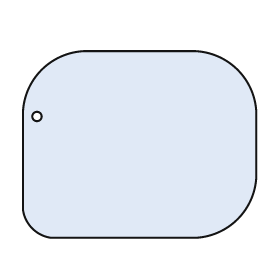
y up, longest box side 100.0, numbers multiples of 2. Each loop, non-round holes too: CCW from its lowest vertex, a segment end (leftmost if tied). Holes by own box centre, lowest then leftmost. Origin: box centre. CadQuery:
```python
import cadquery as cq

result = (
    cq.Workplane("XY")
    .moveTo(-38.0, -40.0)
    .lineTo(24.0, -40.0)
    .threePointArc((42.0, -32.0), (50.0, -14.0))
    .lineTo(50.0, 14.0)
    .threePointArc((42.0, 32.0), (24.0, 40.0))
    .lineTo(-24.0, 40.0)
    .threePointArc((-42.0, 32.0), (-50.0, 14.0))
    .lineTo(-50.0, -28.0)
    .threePointArc((-46.0, -36.0), (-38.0, -40.0))
    .close()
    .moveTo(-44.0, 12.0)
    .circle(2.0)
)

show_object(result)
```